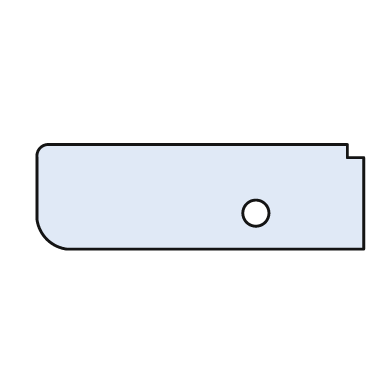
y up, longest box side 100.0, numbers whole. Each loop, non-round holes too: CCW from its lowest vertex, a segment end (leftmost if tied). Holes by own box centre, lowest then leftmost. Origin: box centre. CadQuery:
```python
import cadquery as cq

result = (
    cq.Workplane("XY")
    .moveTo(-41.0, -16.0)
    .lineTo(50.0, -16.0)
    .lineTo(50.0, 12.0)
    .lineTo(45.0, 12.0)
    .lineTo(45.0, 16.0)
    .lineTo(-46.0, 16.0)
    .threePointArc((-49.0, 15.0), (-50.0, 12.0))
    .lineTo(-50.0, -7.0)
    .threePointArc((-47.0, -13.0), (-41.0, -16.0))
    .close()
    .moveTo(17.0, -5.0)
    .circle(4.0)
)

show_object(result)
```